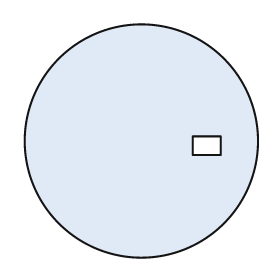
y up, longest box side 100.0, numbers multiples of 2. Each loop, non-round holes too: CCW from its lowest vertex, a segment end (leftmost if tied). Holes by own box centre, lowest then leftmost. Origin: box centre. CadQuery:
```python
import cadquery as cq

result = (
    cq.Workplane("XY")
    .moveTo(0.0, 0.0)
    .circle(50.0)
    .moveTo(22.0, -6.0)
    .lineTo(34.0, -6.0)
    .lineTo(34.0, 2.0)
    .lineTo(22.0, 2.0)
    .close()
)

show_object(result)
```